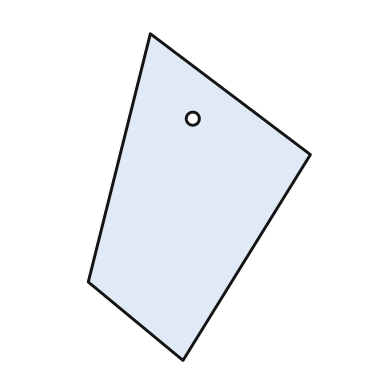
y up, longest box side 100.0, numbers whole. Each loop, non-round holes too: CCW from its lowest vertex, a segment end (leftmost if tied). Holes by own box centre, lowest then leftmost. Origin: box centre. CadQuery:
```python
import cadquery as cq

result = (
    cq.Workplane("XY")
    .moveTo(-5.0, -50.0)
    .lineTo(34.0, 13.0)
    .lineTo(-15.0, 50.0)
    .lineTo(-34.0, -26.0)
    .close()
    .moveTo(-2.0, 24.0)
    .circle(2.0)
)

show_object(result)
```